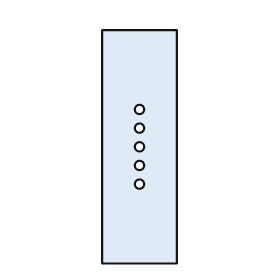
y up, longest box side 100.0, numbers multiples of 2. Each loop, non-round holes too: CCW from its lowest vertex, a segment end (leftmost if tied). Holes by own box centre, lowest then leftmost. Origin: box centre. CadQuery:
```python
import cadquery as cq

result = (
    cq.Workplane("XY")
    .moveTo(-16.0, -50.0)
    .lineTo(16.0, -50.0)
    .lineTo(16.0, 50.0)
    .lineTo(-16.0, 50.0)
    .close()
    .moveTo(0.0, -16.0)
    .circle(2.0)
    .moveTo(0.0, -8.0)
    .circle(2.0)
    .moveTo(0.0, 0.0)
    .circle(2.0)
    .moveTo(0.0, 8.0)
    .circle(2.0)
    .moveTo(0.0, 16.0)
    .circle(2.0)
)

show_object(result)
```